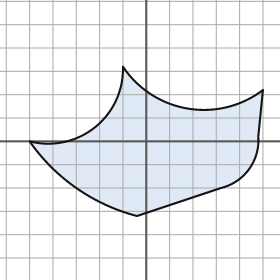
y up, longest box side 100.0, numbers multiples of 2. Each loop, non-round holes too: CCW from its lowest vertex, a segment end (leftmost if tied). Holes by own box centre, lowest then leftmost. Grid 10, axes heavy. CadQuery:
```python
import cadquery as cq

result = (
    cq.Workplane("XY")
    .moveTo(-4.0, -32.0)
    .lineTo(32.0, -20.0)
    .threePointArc((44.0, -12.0), (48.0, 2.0))
    .lineTo(50.0, 22.0)
    .threePointArc((18.0, 14.0), (-10.0, 32.0))
    .threePointArc((-22.0, 6.0), (-50.0, 0.0))
    .threePointArc((-30.0, -20.0), (-4.0, -32.0))
    .close()
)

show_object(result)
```